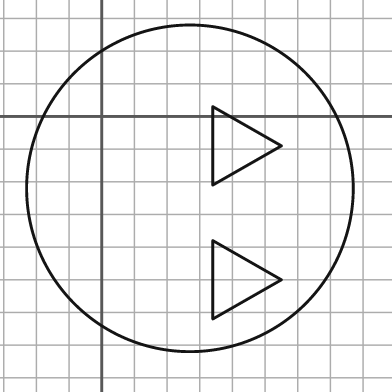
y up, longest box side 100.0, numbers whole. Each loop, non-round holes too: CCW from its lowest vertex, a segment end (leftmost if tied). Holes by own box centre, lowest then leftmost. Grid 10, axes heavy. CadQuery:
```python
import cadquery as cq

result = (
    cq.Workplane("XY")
    .moveTo(27.0, -22.0)
    .circle(50.0)
    .moveTo(34.0, -62.0)
    .lineTo(55.0, -50.0)
    .lineTo(34.0, -38.0)
    .close()
    .moveTo(34.0, -21.0)
    .lineTo(55.0, -9.0)
    .lineTo(34.0, 3.0)
    .close()
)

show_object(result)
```